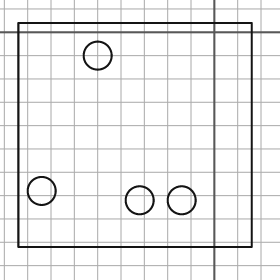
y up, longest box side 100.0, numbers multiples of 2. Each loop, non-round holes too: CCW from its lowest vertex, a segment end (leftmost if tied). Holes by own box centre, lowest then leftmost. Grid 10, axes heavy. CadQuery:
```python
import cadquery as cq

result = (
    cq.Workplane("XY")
    .moveTo(-84.0, -92.0)
    .lineTo(16.0, -92.0)
    .lineTo(16.0, 4.0)
    .lineTo(-84.0, 4.0)
    .close()
    .moveTo(-32.0, -72.0)
    .circle(6.0)
    .moveTo(-14.0, -72.0)
    .circle(6.0)
    .moveTo(-74.0, -68.0)
    .circle(6.0)
    .moveTo(-50.0, -10.0)
    .circle(6.0)
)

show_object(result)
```